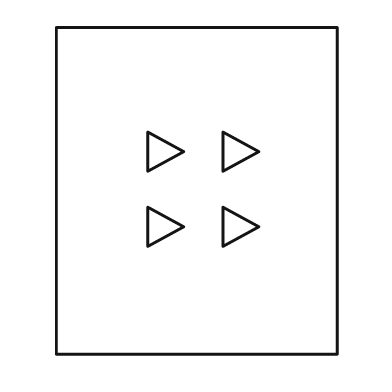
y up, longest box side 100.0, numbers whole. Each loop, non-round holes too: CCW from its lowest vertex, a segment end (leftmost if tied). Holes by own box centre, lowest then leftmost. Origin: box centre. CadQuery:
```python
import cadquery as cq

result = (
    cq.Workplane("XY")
    .moveTo(-43.0, -50.0)
    .lineTo(43.0, -50.0)
    .lineTo(43.0, 50.0)
    .lineTo(-43.0, 50.0)
    .close()
    .moveTo(-15.0, -17.0)
    .lineTo(-4.0, -11.0)
    .lineTo(-15.0, -5.0)
    .close()
    .moveTo(8.0, -17.0)
    .lineTo(19.0, -11.0)
    .lineTo(8.0, -5.0)
    .close()
    .moveTo(-15.0, 6.0)
    .lineTo(-4.0, 12.0)
    .lineTo(-15.0, 18.0)
    .close()
    .moveTo(8.0, 6.0)
    .lineTo(19.0, 12.0)
    .lineTo(8.0, 18.0)
    .close()
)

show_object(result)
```